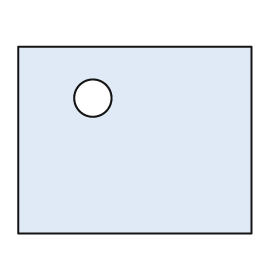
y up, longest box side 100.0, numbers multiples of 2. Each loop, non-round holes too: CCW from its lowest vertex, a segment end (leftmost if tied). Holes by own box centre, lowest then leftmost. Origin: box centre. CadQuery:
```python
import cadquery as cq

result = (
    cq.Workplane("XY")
    .moveTo(-50.0, -40.0)
    .lineTo(50.0, -40.0)
    .lineTo(50.0, 40.0)
    .lineTo(-50.0, 40.0)
    .close()
    .moveTo(-18.0, 18.0)
    .circle(8.0)
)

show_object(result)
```